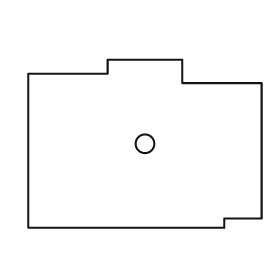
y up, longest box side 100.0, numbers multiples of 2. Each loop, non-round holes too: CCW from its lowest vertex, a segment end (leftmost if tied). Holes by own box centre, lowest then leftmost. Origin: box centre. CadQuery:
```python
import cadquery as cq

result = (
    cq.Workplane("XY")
    .moveTo(-50.0, -36.0)
    .lineTo(34.0, -36.0)
    .lineTo(34.0, -32.0)
    .lineTo(50.0, -32.0)
    .lineTo(50.0, 26.0)
    .lineTo(16.0, 26.0)
    .lineTo(16.0, 36.0)
    .lineTo(-16.0, 36.0)
    .lineTo(-16.0, 30.0)
    .lineTo(-50.0, 30.0)
    .close()
    .moveTo(0.0, 0.0)
    .circle(4.0)
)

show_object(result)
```